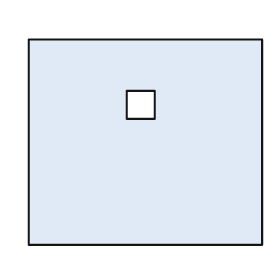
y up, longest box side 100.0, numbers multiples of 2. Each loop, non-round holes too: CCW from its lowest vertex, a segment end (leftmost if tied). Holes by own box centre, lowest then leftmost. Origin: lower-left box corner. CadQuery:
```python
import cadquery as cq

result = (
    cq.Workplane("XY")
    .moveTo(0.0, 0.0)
    .lineTo(100.0, 0.0)
    .lineTo(100.0, 88.0)
    .lineTo(0.0, 88.0)
    .close()
    .moveTo(42.0, 54.0)
    .lineTo(54.0, 54.0)
    .lineTo(54.0, 66.0)
    .lineTo(42.0, 66.0)
    .close()
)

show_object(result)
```